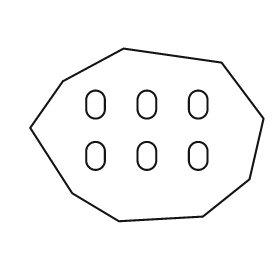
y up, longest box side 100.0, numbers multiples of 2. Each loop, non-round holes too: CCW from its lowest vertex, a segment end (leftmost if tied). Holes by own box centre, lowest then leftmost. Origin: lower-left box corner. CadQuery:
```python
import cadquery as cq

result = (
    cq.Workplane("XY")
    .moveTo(38.0, 0.0)
    .lineTo(74.0, 2.0)
    .lineTo(94.0, 18.0)
    .lineTo(100.0, 44.0)
    .lineTo(82.0, 68.0)
    .lineTo(40.0, 74.0)
    .lineTo(14.0, 60.0)
    .lineTo(0.0, 40.0)
    .lineTo(18.0, 12.0)
    .close()
    .moveTo(24.0, 26.0)
    .threePointArc((28.0, 22.0), (32.0, 26.0))
    .lineTo(32.0, 30.0)
    .threePointArc((28.0, 34.0), (24.0, 30.0))
    .close()
    .moveTo(46.0, 26.0)
    .threePointArc((50.0, 22.0), (54.0, 26.0))
    .lineTo(54.0, 30.0)
    .threePointArc((50.0, 34.0), (46.0, 30.0))
    .close()
    .moveTo(68.0, 26.0)
    .threePointArc((72.0, 22.0), (76.0, 26.0))
    .lineTo(76.0, 30.0)
    .threePointArc((72.0, 34.0), (68.0, 30.0))
    .close()
    .moveTo(24.0, 48.0)
    .threePointArc((28.0, 44.0), (32.0, 48.0))
    .lineTo(32.0, 52.0)
    .threePointArc((28.0, 56.0), (24.0, 52.0))
    .close()
    .moveTo(46.0, 48.0)
    .threePointArc((50.0, 44.0), (54.0, 48.0))
    .lineTo(54.0, 52.0)
    .threePointArc((50.0, 56.0), (46.0, 52.0))
    .close()
    .moveTo(68.0, 48.0)
    .threePointArc((72.0, 44.0), (76.0, 48.0))
    .lineTo(76.0, 52.0)
    .threePointArc((72.0, 56.0), (68.0, 52.0))
    .close()
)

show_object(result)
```